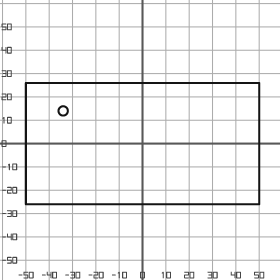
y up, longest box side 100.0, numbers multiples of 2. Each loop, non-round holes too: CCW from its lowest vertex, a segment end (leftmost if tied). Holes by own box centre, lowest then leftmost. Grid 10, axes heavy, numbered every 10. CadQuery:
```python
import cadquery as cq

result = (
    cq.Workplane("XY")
    .moveTo(-50.0, -26.0)
    .lineTo(50.0, -26.0)
    .lineTo(50.0, 26.0)
    .lineTo(-50.0, 26.0)
    .close()
    .moveTo(-34.0, 14.0)
    .circle(2.0)
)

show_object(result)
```